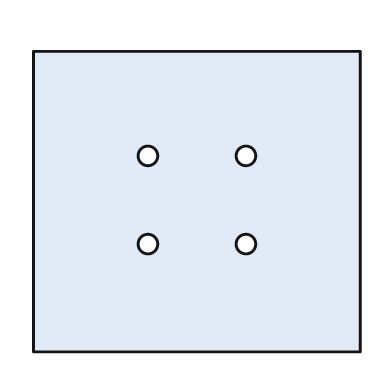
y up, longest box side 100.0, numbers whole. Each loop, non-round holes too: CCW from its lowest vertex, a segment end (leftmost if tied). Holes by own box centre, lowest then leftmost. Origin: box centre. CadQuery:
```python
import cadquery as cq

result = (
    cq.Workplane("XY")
    .moveTo(-50.0, -46.0)
    .lineTo(50.0, -46.0)
    .lineTo(50.0, 46.0)
    .lineTo(-50.0, 46.0)
    .close()
    .moveTo(-15.0, -13.0)
    .circle(3.0)
    .moveTo(15.0, -13.0)
    .circle(3.0)
    .moveTo(-15.0, 14.0)
    .circle(3.0)
    .moveTo(15.0, 14.0)
    .circle(3.0)
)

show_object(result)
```